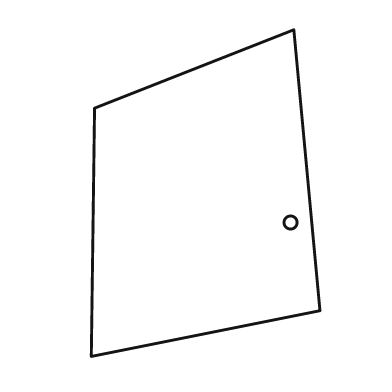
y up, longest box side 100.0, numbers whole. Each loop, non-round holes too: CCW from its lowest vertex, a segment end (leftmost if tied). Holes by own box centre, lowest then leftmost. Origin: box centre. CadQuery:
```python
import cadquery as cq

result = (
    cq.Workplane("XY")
    .moveTo(-35.0, -50.0)
    .lineTo(35.0, -36.0)
    .lineTo(27.0, 50.0)
    .lineTo(-34.0, 26.0)
    .close()
    .moveTo(26.0, -9.0)
    .circle(2.0)
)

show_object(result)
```